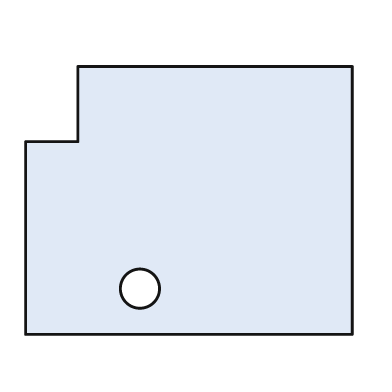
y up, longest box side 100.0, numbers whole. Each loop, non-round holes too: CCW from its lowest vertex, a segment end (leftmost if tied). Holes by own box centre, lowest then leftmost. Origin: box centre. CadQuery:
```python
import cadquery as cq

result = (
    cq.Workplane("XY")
    .moveTo(-50.0, -41.0)
    .lineTo(50.0, -41.0)
    .lineTo(50.0, 41.0)
    .lineTo(-34.0, 41.0)
    .lineTo(-34.0, 18.0)
    .lineTo(-50.0, 18.0)
    .close()
    .moveTo(-15.0, -27.0)
    .circle(6.0)
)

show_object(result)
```